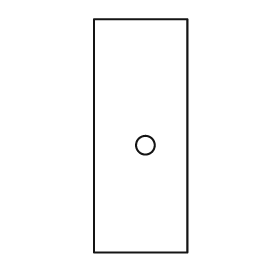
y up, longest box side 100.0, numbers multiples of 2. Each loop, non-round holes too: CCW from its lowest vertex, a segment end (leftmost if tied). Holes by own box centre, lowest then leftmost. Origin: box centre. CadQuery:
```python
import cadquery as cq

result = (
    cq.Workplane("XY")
    .moveTo(-20.0, -50.0)
    .lineTo(20.0, -50.0)
    .lineTo(20.0, 50.0)
    .lineTo(-20.0, 50.0)
    .close()
    .moveTo(2.0, -4.0)
    .circle(4.0)
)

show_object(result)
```